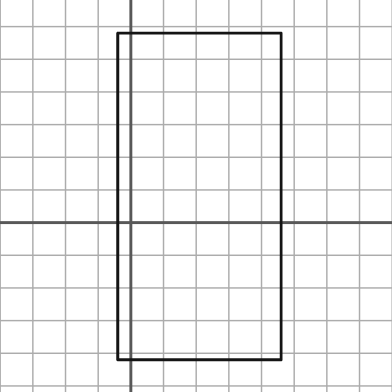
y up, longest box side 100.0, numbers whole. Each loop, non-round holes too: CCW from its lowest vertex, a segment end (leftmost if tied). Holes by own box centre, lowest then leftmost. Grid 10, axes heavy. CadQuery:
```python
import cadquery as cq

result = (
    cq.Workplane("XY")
    .moveTo(-4.0, -42.0)
    .lineTo(46.0, -42.0)
    .lineTo(46.0, 58.0)
    .lineTo(-4.0, 58.0)
    .close()
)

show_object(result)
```